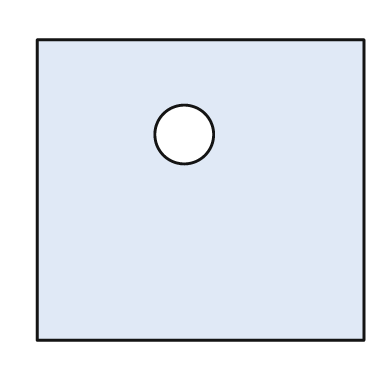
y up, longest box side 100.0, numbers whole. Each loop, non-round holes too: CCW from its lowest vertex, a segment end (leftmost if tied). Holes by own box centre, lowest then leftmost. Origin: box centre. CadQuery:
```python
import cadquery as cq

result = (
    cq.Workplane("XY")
    .moveTo(-50.0, -46.0)
    .lineTo(50.0, -46.0)
    .lineTo(50.0, 46.0)
    .lineTo(-50.0, 46.0)
    .close()
    .moveTo(-5.0, 17.0)
    .circle(9.0)
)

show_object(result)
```